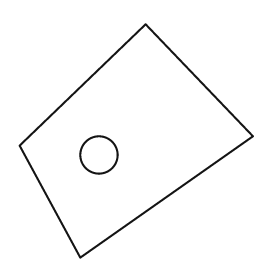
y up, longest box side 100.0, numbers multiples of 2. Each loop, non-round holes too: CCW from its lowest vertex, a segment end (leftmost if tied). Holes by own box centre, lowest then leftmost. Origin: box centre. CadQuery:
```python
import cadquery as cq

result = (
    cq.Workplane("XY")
    .moveTo(-24.0, -50.0)
    .lineTo(50.0, 2.0)
    .lineTo(4.0, 50.0)
    .lineTo(-50.0, -2.0)
    .close()
    .moveTo(-16.0, -6.0)
    .circle(8.0)
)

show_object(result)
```